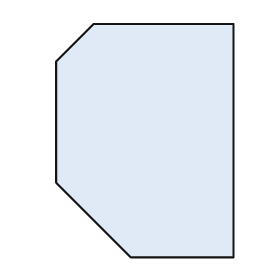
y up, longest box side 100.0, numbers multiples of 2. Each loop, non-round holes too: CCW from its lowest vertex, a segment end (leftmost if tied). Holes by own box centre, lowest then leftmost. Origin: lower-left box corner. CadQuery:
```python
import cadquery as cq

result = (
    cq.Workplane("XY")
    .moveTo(32.0, 0.0)
    .lineTo(76.0, 0.0)
    .lineTo(76.0, 100.0)
    .lineTo(16.0, 100.0)
    .lineTo(0.0, 84.0)
    .lineTo(0.0, 32.0)
    .close()
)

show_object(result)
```